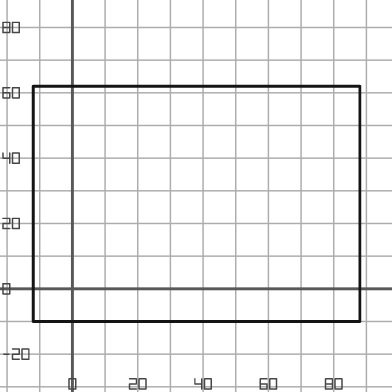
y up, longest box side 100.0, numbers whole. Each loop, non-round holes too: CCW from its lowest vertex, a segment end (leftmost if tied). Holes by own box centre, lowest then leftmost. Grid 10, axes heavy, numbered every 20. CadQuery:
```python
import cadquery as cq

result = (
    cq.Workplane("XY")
    .moveTo(-12.0, -10.0)
    .lineTo(88.0, -10.0)
    .lineTo(88.0, 62.0)
    .lineTo(-12.0, 62.0)
    .close()
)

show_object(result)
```